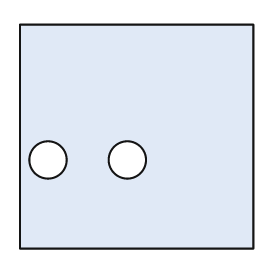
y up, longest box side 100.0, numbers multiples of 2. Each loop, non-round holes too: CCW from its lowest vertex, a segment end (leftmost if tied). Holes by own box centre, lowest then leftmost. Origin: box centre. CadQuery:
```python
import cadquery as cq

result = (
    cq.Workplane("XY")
    .moveTo(-50.0, -48.0)
    .lineTo(50.0, -48.0)
    .lineTo(50.0, 48.0)
    .lineTo(-50.0, 48.0)
    .close()
    .moveTo(-38.0, -10.0)
    .circle(8.0)
    .moveTo(-4.0, -10.0)
    .circle(8.0)
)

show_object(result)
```